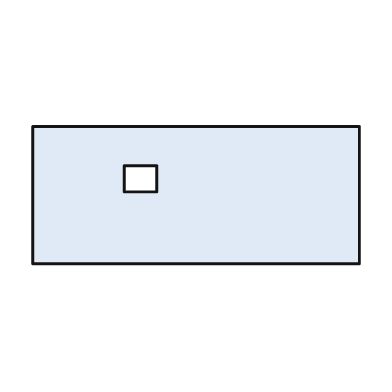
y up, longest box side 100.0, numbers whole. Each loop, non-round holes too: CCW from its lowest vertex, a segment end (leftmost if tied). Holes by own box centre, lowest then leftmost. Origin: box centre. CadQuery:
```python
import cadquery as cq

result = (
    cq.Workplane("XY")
    .moveTo(-50.0, -21.0)
    .lineTo(50.0, -21.0)
    .lineTo(50.0, 21.0)
    .lineTo(-50.0, 21.0)
    .close()
    .moveTo(-22.0, 1.0)
    .lineTo(-12.0, 1.0)
    .lineTo(-12.0, 9.0)
    .lineTo(-22.0, 9.0)
    .close()
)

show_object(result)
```